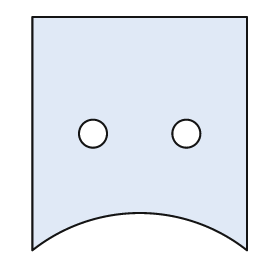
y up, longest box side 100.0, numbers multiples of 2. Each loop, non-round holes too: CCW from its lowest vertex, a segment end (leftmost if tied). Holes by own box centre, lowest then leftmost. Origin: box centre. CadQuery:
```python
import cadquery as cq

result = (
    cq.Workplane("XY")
    .moveTo(-46.0, -50.0)
    .threePointArc((0.0, -34.0), (46.0, -50.0))
    .lineTo(46.0, 50.0)
    .lineTo(-46.0, 50.0)
    .close()
    .moveTo(-20.0, 0.0)
    .circle(6.0)
    .moveTo(20.0, 0.0)
    .circle(6.0)
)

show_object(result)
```